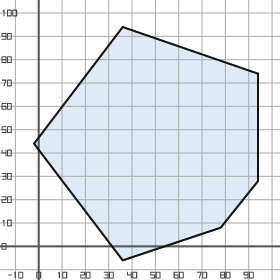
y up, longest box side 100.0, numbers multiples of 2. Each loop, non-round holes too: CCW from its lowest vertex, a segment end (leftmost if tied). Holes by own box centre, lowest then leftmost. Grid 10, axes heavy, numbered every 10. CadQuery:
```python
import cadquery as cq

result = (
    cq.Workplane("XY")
    .moveTo(36.0, -6.0)
    .lineTo(78.0, 8.0)
    .lineTo(94.0, 28.0)
    .lineTo(94.0, 74.0)
    .lineTo(36.0, 94.0)
    .lineTo(-2.0, 44.0)
    .close()
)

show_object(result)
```